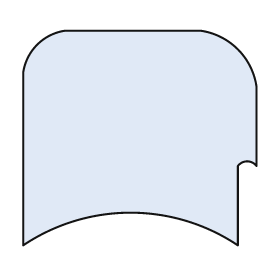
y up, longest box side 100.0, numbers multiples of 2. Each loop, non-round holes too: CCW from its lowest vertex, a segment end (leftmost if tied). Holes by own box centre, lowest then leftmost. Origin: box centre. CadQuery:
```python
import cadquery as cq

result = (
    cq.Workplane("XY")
    .moveTo(-50.0, -46.0)
    .threePointArc((-4.0, -32.0), (42.0, -46.0))
    .lineTo(42.0, -12.0)
    .threePointArc((46.0, -10.0), (50.0, -12.0))
    .lineTo(50.0, 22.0)
    .threePointArc((42.0, 38.0), (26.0, 46.0))
    .lineTo(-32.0, 46.0)
    .threePointArc((-44.0, 40.0), (-50.0, 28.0))
    .close()
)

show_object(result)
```